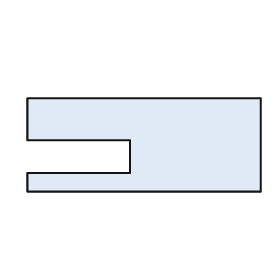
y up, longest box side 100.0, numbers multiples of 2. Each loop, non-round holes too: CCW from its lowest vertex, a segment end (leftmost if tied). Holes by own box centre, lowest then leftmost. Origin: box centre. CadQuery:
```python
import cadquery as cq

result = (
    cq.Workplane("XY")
    .moveTo(-50.0, -20.0)
    .lineTo(50.0, -20.0)
    .lineTo(50.0, 20.0)
    .lineTo(-50.0, 20.0)
    .lineTo(-50.0, 2.0)
    .lineTo(-6.0, 2.0)
    .lineTo(-6.0, -12.0)
    .lineTo(-50.0, -12.0)
    .close()
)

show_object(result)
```